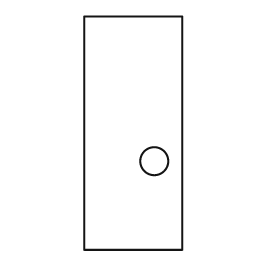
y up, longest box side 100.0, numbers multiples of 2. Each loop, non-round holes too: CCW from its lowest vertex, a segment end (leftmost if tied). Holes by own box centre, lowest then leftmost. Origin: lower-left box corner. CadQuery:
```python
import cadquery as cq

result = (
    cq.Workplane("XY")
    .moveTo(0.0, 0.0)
    .lineTo(42.0, 0.0)
    .lineTo(42.0, 100.0)
    .lineTo(0.0, 100.0)
    .close()
    .moveTo(30.0, 38.0)
    .circle(6.0)
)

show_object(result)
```